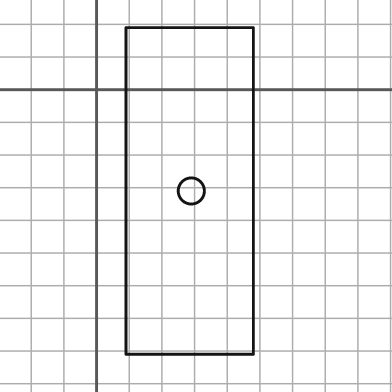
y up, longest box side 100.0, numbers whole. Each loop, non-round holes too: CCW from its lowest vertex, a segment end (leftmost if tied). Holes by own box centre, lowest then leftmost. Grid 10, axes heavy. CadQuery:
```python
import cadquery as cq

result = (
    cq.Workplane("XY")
    .moveTo(9.0, -81.0)
    .lineTo(48.0, -81.0)
    .lineTo(48.0, 19.0)
    .lineTo(9.0, 19.0)
    .close()
    .moveTo(29.0, -31.0)
    .circle(4.0)
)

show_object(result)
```